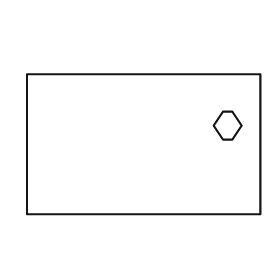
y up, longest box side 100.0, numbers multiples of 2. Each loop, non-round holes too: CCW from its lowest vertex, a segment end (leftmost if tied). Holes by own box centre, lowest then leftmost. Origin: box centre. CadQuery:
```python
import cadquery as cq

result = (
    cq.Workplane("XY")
    .moveTo(-50.0, -30.0)
    .lineTo(50.0, -30.0)
    .lineTo(50.0, 30.0)
    .lineTo(-50.0, 30.0)
    .close()
    .moveTo(34.0, 2.0)
    .lineTo(38.0, 2.0)
    .lineTo(42.0, 8.0)
    .lineTo(38.0, 14.0)
    .lineTo(34.0, 14.0)
    .lineTo(30.0, 8.0)
    .close()
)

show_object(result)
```